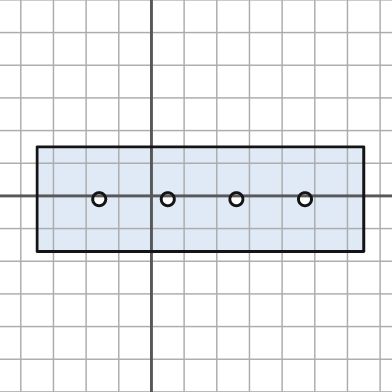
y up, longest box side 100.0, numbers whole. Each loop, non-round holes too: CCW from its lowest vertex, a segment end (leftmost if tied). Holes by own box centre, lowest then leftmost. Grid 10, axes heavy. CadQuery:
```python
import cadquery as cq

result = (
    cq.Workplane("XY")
    .moveTo(-35.0, -17.0)
    .lineTo(65.0, -17.0)
    .lineTo(65.0, 15.0)
    .lineTo(-35.0, 15.0)
    .close()
    .moveTo(-16.0, -1.0)
    .circle(2.0)
    .moveTo(5.0, -1.0)
    .circle(2.0)
    .moveTo(26.0, -1.0)
    .circle(2.0)
    .moveTo(47.0, -1.0)
    .circle(2.0)
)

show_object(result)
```